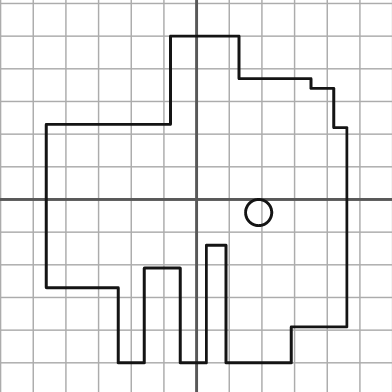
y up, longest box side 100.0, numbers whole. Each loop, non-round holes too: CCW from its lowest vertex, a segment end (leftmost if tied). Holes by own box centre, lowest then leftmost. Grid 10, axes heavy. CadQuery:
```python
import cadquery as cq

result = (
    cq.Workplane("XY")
    .moveTo(-24.0, -50.0)
    .lineTo(-16.0, -50.0)
    .lineTo(-16.0, -21.0)
    .lineTo(-5.0, -21.0)
    .lineTo(-5.0, -50.0)
    .lineTo(3.0, -50.0)
    .lineTo(3.0, -14.0)
    .lineTo(9.0, -14.0)
    .lineTo(9.0, -50.0)
    .lineTo(29.0, -50.0)
    .lineTo(29.0, -39.0)
    .lineTo(46.0, -39.0)
    .lineTo(46.0, 22.0)
    .lineTo(42.0, 22.0)
    .lineTo(42.0, 34.0)
    .lineTo(35.0, 34.0)
    .lineTo(35.0, 37.0)
    .lineTo(13.0, 37.0)
    .lineTo(13.0, 50.0)
    .lineTo(-8.0, 50.0)
    .lineTo(-8.0, 23.0)
    .lineTo(-46.0, 23.0)
    .lineTo(-46.0, -27.0)
    .lineTo(-24.0, -27.0)
    .close()
    .moveTo(19.0, -4.0)
    .circle(4.0)
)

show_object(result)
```